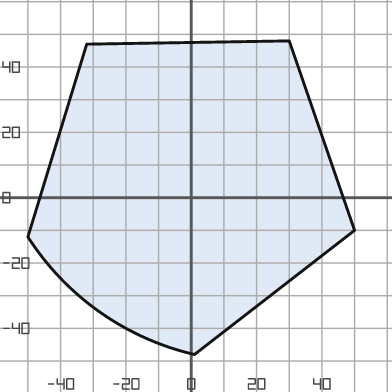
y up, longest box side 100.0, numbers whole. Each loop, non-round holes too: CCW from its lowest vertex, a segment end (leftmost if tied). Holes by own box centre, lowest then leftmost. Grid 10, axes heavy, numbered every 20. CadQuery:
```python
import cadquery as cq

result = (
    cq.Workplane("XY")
    .moveTo(1.0, -48.0)
    .lineTo(50.0, -10.0)
    .lineTo(30.0, 48.0)
    .lineTo(-32.0, 47.0)
    .lineTo(-50.0, -12.0)
    .threePointArc((-28.0, -35.0), (1.0, -48.0))
    .close()
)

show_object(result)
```